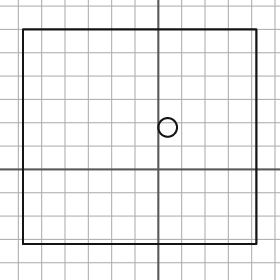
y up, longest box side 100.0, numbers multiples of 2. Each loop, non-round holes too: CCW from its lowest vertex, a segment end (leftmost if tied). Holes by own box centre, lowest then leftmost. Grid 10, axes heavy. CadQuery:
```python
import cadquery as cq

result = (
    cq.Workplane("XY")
    .moveTo(-58.0, -32.0)
    .lineTo(42.0, -32.0)
    .lineTo(42.0, 60.0)
    .lineTo(-58.0, 60.0)
    .close()
    .moveTo(4.0, 18.0)
    .circle(4.0)
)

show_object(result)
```